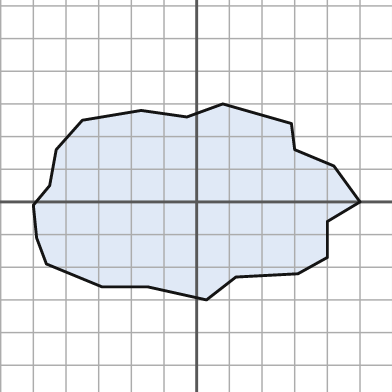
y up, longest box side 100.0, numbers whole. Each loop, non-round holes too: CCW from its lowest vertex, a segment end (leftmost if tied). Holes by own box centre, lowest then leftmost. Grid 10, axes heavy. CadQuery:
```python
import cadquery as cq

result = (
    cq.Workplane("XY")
    .moveTo(3.0, -30.0)
    .lineTo(12.0, -23.0)
    .lineTo(31.0, -22.0)
    .lineTo(40.0, -17.0)
    .lineTo(40.0, -6.0)
    .lineTo(50.0, 0.0)
    .lineTo(42.0, 11.0)
    .lineTo(30.0, 16.0)
    .lineTo(29.0, 24.0)
    .lineTo(8.0, 30.0)
    .lineTo(-3.0, 26.0)
    .lineTo(-17.0, 28.0)
    .lineTo(-35.0, 25.0)
    .lineTo(-43.0, 16.0)
    .lineTo(-45.0, 5.0)
    .lineTo(-50.0, -1.0)
    .lineTo(-49.0, -11.0)
    .lineTo(-46.0, -19.0)
    .lineTo(-29.0, -26.0)
    .lineTo(-15.0, -26.0)
    .close()
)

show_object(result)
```